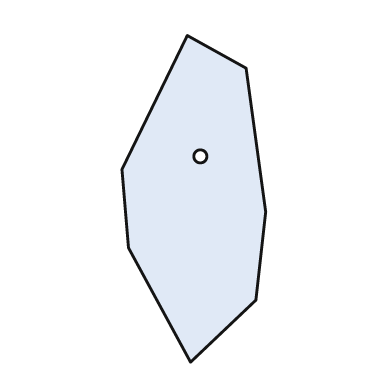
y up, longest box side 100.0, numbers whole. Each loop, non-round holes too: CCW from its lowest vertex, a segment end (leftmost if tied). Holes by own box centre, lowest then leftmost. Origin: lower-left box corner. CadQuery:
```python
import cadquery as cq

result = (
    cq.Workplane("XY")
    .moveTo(21.0, 0.0)
    .lineTo(41.0, 19.0)
    .lineTo(44.0, 46.0)
    .lineTo(38.0, 90.0)
    .lineTo(20.0, 100.0)
    .lineTo(0.0, 59.0)
    .lineTo(2.0, 35.0)
    .close()
    .moveTo(24.0, 63.0)
    .circle(2.0)
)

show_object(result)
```